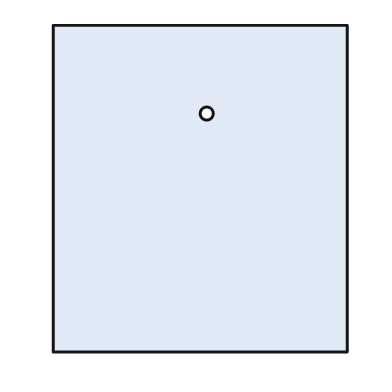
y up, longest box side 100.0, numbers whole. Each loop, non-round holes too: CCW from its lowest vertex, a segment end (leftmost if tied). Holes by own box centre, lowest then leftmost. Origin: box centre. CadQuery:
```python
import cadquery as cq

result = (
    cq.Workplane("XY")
    .moveTo(-45.0, -50.0)
    .lineTo(45.0, -50.0)
    .lineTo(45.0, 50.0)
    .lineTo(-45.0, 50.0)
    .close()
    .moveTo(2.0, 23.0)
    .circle(2.0)
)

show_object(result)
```